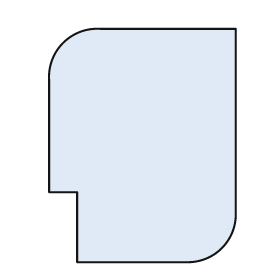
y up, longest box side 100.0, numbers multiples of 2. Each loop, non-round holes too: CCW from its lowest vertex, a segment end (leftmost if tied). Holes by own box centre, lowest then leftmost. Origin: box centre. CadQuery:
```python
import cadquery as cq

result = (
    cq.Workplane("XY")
    .moveTo(-28.0, -50.0)
    .lineTo(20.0, -50.0)
    .threePointArc((34.0, -44.0), (40.0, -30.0))
    .lineTo(40.0, 50.0)
    .lineTo(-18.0, 50.0)
    .threePointArc((-34.0, 44.0), (-40.0, 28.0))
    .lineTo(-40.0, -20.0)
    .lineTo(-28.0, -20.0)
    .close()
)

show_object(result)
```